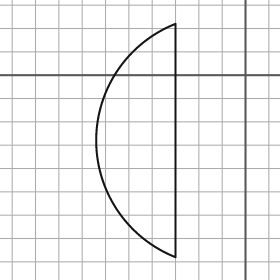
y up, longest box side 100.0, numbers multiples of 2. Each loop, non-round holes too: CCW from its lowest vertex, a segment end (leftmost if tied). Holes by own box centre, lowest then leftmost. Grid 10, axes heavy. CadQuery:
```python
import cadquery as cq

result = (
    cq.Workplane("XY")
    .moveTo(-30.0, -78.0)
    .lineTo(-30.0, 22.0)
    .threePointArc((-64.0, -28.0), (-30.0, -78.0))
    .close()
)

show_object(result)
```